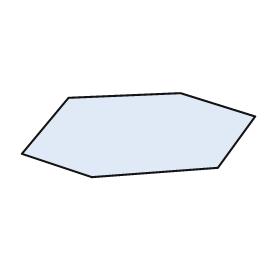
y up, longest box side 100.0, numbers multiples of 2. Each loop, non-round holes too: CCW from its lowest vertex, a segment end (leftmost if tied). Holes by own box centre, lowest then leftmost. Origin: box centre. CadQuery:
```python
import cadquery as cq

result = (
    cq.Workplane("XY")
    .moveTo(-20.0, -18.0)
    .lineTo(34.0, -14.0)
    .lineTo(50.0, 8.0)
    .lineTo(18.0, 18.0)
    .lineTo(-30.0, 16.0)
    .lineTo(-50.0, -8.0)
    .close()
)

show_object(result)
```